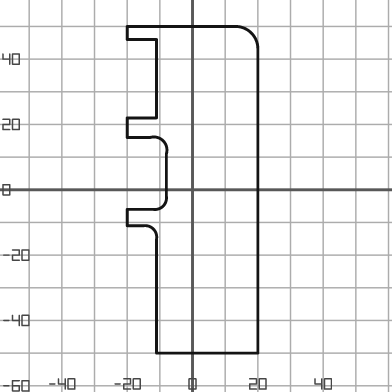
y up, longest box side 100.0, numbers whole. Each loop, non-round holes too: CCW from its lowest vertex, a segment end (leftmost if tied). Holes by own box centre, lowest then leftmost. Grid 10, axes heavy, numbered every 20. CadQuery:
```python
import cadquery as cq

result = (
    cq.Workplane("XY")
    .moveTo(-11.0, -50.0)
    .lineTo(20.0, -50.0)
    .lineTo(20.0, 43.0)
    .threePointArc((18.0, 48.0), (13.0, 50.0))
    .lineTo(-20.0, 50.0)
    .lineTo(-20.0, 46.0)
    .lineTo(-11.0, 46.0)
    .lineTo(-11.0, 22.0)
    .lineTo(-20.0, 22.0)
    .lineTo(-20.0, 16.0)
    .lineTo(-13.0, 16.0)
    .threePointArc((-9.0, 15.0), (-8.0, 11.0))
    .lineTo(-8.0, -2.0)
    .threePointArc((-9.0, -5.0), (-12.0, -6.0))
    .lineTo(-20.0, -6.0)
    .lineTo(-20.0, -11.0)
    .lineTo(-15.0, -11.0)
    .threePointArc((-12.0, -12.0), (-11.0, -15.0))
    .close()
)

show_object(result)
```